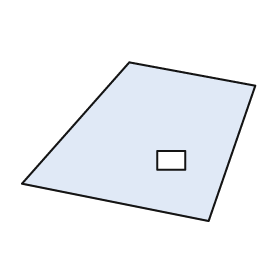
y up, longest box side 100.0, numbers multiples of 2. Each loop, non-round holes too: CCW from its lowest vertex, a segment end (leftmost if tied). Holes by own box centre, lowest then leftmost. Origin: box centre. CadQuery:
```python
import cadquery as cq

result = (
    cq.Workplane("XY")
    .moveTo(30.0, -34.0)
    .lineTo(50.0, 24.0)
    .lineTo(-4.0, 34.0)
    .lineTo(-50.0, -18.0)
    .close()
    .moveTo(8.0, -12.0)
    .lineTo(20.0, -12.0)
    .lineTo(20.0, -4.0)
    .lineTo(8.0, -4.0)
    .close()
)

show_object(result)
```